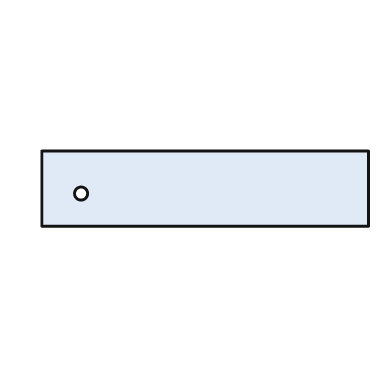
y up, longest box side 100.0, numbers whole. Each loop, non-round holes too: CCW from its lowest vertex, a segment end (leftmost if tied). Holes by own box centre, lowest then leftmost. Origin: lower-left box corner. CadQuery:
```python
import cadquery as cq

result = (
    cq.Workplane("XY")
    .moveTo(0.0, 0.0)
    .lineTo(100.0, 0.0)
    .lineTo(100.0, 23.0)
    .lineTo(0.0, 23.0)
    .close()
    .moveTo(12.0, 10.0)
    .circle(2.0)
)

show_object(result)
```